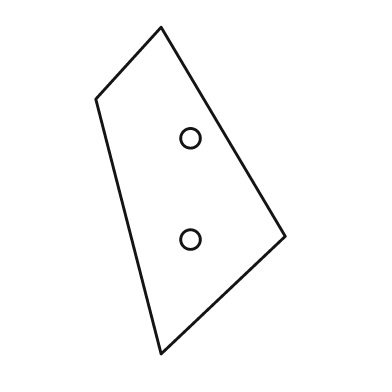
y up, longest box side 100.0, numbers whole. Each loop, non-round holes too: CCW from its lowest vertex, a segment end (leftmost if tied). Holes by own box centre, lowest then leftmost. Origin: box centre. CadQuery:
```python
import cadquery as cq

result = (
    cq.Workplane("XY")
    .moveTo(-9.0, -50.0)
    .lineTo(29.0, -14.0)
    .lineTo(-9.0, 50.0)
    .lineTo(-29.0, 28.0)
    .close()
    .moveTo(0.0, -15.0)
    .circle(3.0)
    .moveTo(0.0, 16.0)
    .circle(3.0)
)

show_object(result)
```